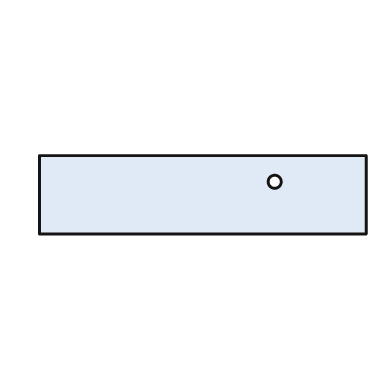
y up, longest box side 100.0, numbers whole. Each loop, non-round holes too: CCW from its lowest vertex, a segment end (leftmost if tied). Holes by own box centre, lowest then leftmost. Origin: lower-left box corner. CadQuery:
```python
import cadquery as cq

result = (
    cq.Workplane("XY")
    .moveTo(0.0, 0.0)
    .lineTo(100.0, 0.0)
    .lineTo(100.0, 24.0)
    .lineTo(0.0, 24.0)
    .close()
    .moveTo(72.0, 16.0)
    .circle(2.0)
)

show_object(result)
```